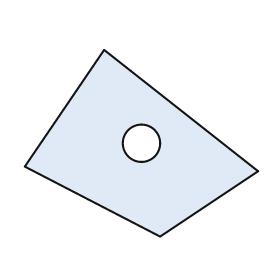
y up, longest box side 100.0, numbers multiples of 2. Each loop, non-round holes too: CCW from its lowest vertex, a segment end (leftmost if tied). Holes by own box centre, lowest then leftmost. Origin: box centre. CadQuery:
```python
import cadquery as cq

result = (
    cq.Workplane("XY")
    .moveTo(8.0, -40.0)
    .lineTo(50.0, -12.0)
    .lineTo(-16.0, 40.0)
    .lineTo(-50.0, -10.0)
    .close()
    .moveTo(0.0, 0.0)
    .circle(8.0)
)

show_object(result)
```